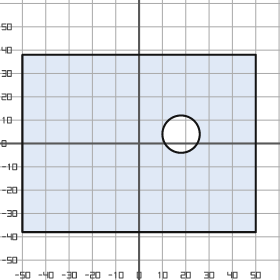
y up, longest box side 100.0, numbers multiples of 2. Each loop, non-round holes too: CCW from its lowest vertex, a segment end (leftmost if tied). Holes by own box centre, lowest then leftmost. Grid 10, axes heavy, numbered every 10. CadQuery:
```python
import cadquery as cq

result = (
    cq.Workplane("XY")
    .moveTo(-50.0, -38.0)
    .lineTo(50.0, -38.0)
    .lineTo(50.0, 38.0)
    .lineTo(-50.0, 38.0)
    .close()
    .moveTo(18.0, 4.0)
    .circle(8.0)
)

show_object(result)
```